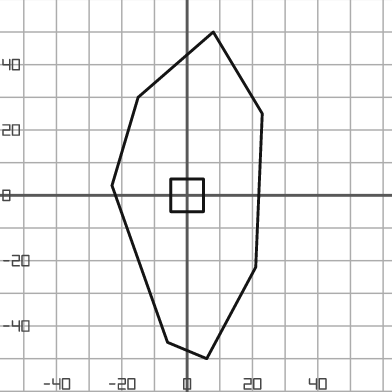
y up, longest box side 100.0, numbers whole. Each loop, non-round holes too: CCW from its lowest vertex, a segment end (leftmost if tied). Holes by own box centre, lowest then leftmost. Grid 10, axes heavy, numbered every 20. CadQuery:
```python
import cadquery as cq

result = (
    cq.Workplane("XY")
    .moveTo(6.0, -50.0)
    .lineTo(21.0, -22.0)
    .lineTo(23.0, 25.0)
    .lineTo(8.0, 50.0)
    .lineTo(-15.0, 30.0)
    .lineTo(-23.0, 3.0)
    .lineTo(-6.0, -45.0)
    .close()
    .moveTo(-5.0, -5.0)
    .lineTo(5.0, -5.0)
    .lineTo(5.0, 5.0)
    .lineTo(-5.0, 5.0)
    .close()
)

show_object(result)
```